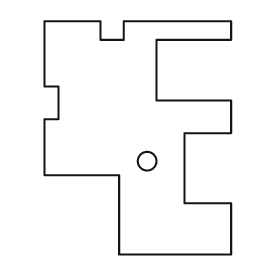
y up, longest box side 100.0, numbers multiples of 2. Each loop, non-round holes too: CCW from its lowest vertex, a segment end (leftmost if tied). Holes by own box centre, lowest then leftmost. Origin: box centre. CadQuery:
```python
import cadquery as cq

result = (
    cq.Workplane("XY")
    .moveTo(-8.0, -50.0)
    .lineTo(40.0, -50.0)
    .lineTo(40.0, -28.0)
    .lineTo(20.0, -28.0)
    .lineTo(20.0, 2.0)
    .lineTo(40.0, 2.0)
    .lineTo(40.0, 16.0)
    .lineTo(8.0, 16.0)
    .lineTo(8.0, 42.0)
    .lineTo(40.0, 42.0)
    .lineTo(40.0, 50.0)
    .lineTo(-6.0, 50.0)
    .lineTo(-6.0, 42.0)
    .lineTo(-16.0, 42.0)
    .lineTo(-16.0, 50.0)
    .lineTo(-40.0, 50.0)
    .lineTo(-40.0, 22.0)
    .lineTo(-34.0, 22.0)
    .lineTo(-34.0, 8.0)
    .lineTo(-40.0, 8.0)
    .lineTo(-40.0, -16.0)
    .lineTo(-8.0, -16.0)
    .close()
    .moveTo(4.0, -10.0)
    .circle(4.0)
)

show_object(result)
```